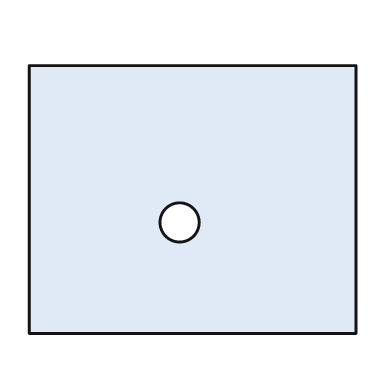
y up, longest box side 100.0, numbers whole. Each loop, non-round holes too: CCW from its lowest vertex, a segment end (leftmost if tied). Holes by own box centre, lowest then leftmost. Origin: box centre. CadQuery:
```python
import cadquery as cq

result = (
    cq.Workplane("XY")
    .moveTo(-50.0, -41.0)
    .lineTo(50.0, -41.0)
    .lineTo(50.0, 41.0)
    .lineTo(-50.0, 41.0)
    .close()
    .moveTo(-4.0, -7.0)
    .circle(6.0)
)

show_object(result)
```